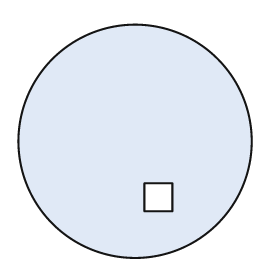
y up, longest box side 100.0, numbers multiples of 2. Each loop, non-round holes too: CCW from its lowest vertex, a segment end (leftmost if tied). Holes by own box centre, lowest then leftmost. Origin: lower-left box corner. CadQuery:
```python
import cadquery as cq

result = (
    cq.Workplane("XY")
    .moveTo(50.0, 50.0)
    .circle(50.0)
    .moveTo(54.0, 20.0)
    .lineTo(66.0, 20.0)
    .lineTo(66.0, 32.0)
    .lineTo(54.0, 32.0)
    .close()
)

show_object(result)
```